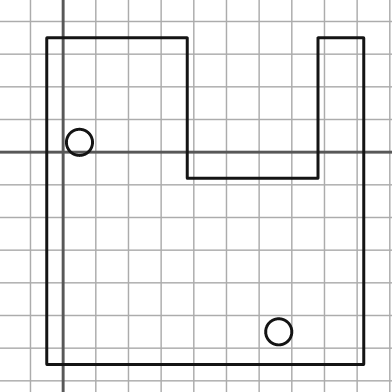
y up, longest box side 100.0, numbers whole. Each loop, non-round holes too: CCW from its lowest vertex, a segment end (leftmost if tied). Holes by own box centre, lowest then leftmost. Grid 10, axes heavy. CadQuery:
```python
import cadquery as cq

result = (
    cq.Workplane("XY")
    .moveTo(-5.0, -65.0)
    .lineTo(92.0, -65.0)
    .lineTo(92.0, 35.0)
    .lineTo(78.0, 35.0)
    .lineTo(78.0, -8.0)
    .lineTo(38.0, -8.0)
    .lineTo(38.0, 35.0)
    .lineTo(-5.0, 35.0)
    .close()
    .moveTo(66.0, -55.0)
    .circle(4.0)
    .moveTo(5.0, 3.0)
    .circle(4.0)
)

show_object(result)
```